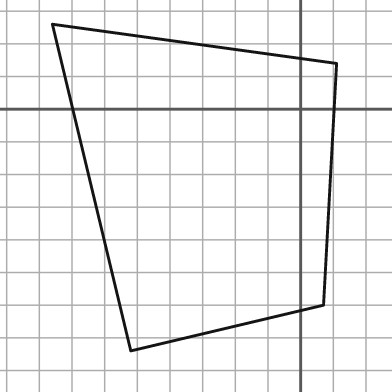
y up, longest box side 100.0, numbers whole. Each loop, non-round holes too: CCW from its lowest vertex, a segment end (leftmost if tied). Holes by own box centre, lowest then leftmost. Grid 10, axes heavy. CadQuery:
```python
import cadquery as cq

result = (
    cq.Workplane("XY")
    .moveTo(-52.0, -74.0)
    .lineTo(7.0, -60.0)
    .lineTo(11.0, 14.0)
    .lineTo(-76.0, 26.0)
    .close()
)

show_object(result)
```